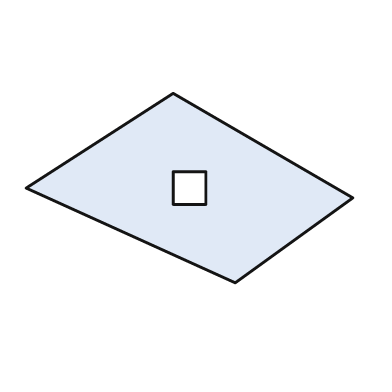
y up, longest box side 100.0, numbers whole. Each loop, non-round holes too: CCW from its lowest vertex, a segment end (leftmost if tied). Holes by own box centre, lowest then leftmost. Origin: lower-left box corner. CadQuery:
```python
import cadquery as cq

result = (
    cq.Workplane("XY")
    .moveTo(64.0, 0.0)
    .lineTo(100.0, 26.0)
    .lineTo(45.0, 58.0)
    .lineTo(0.0, 29.0)
    .close()
    .moveTo(45.0, 24.0)
    .lineTo(55.0, 24.0)
    .lineTo(55.0, 34.0)
    .lineTo(45.0, 34.0)
    .close()
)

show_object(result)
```